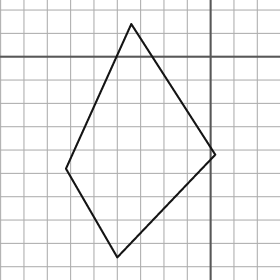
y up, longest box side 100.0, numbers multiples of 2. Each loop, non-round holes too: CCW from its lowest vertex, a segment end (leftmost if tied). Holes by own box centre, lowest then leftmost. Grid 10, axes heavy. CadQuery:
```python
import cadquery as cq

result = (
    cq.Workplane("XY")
    .moveTo(-40.0, -86.0)
    .lineTo(2.0, -42.0)
    .lineTo(-34.0, 14.0)
    .lineTo(-62.0, -48.0)
    .close()
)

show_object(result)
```